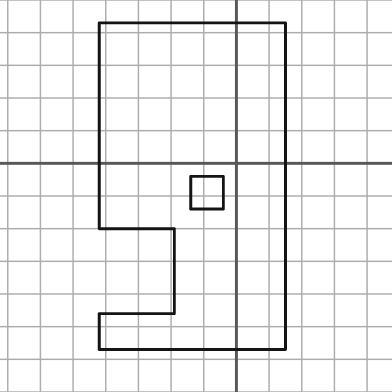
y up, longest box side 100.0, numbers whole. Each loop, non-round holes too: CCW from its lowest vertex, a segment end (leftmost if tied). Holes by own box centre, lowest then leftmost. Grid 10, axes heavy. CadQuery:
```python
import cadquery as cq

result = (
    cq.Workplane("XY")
    .moveTo(-42.0, -57.0)
    .lineTo(15.0, -57.0)
    .lineTo(15.0, 43.0)
    .lineTo(-42.0, 43.0)
    .lineTo(-42.0, -20.0)
    .lineTo(-19.0, -20.0)
    .lineTo(-19.0, -46.0)
    .lineTo(-42.0, -46.0)
    .close()
    .moveTo(-14.0, -14.0)
    .lineTo(-4.0, -14.0)
    .lineTo(-4.0, -4.0)
    .lineTo(-14.0, -4.0)
    .close()
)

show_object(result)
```